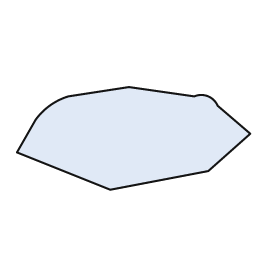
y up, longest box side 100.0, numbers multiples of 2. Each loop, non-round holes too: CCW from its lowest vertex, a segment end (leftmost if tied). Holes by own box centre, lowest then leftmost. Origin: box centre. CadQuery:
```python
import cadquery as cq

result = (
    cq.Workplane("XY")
    .moveTo(-10.0, -22.0)
    .lineTo(32.0, -14.0)
    .lineTo(50.0, 2.0)
    .lineTo(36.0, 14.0)
    .threePointArc((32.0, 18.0), (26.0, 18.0))
    .lineTo(-2.0, 22.0)
    .lineTo(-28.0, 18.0)
    .threePointArc((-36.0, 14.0), (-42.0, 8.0))
    .lineTo(-50.0, -6.0)
    .close()
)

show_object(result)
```